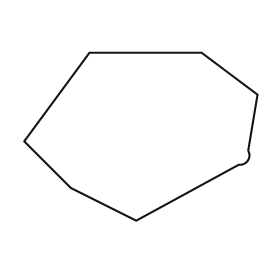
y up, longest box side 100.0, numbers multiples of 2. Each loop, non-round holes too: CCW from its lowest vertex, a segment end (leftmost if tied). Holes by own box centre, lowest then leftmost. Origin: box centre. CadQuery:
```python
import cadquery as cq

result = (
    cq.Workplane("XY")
    .moveTo(-2.0, -36.0)
    .lineTo(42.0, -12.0)
    .threePointArc((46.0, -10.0), (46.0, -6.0))
    .lineTo(50.0, 18.0)
    .lineTo(26.0, 36.0)
    .lineTo(-22.0, 36.0)
    .lineTo(-50.0, -2.0)
    .lineTo(-30.0, -22.0)
    .close()
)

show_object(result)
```